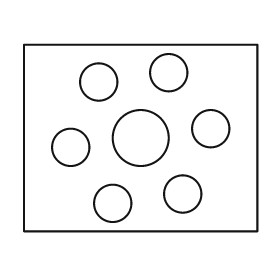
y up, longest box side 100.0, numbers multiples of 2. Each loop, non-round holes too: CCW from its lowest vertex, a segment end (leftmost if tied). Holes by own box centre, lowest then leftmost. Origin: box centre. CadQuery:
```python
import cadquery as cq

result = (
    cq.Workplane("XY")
    .moveTo(-50.0, -40.0)
    .lineTo(50.0, -40.0)
    .lineTo(50.0, 40.0)
    .lineTo(-50.0, 40.0)
    .close()
    .moveTo(-12.0, -28.0)
    .circle(8.0)
    .moveTo(18.0, -24.0)
    .circle(8.0)
    .moveTo(-30.0, -4.0)
    .circle(8.0)
    .moveTo(0.0, 0.0)
    .circle(12.0)
    .moveTo(30.0, 4.0)
    .circle(8.0)
    .moveTo(-18.0, 24.0)
    .circle(8.0)
    .moveTo(12.0, 28.0)
    .circle(8.0)
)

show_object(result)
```